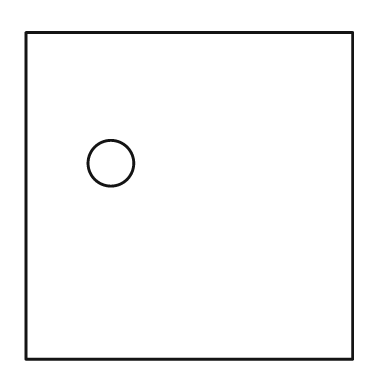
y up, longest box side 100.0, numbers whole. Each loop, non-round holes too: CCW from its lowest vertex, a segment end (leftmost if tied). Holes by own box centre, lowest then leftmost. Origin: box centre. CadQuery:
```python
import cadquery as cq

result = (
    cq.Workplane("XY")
    .moveTo(-50.0, -50.0)
    .lineTo(50.0, -50.0)
    .lineTo(50.0, 50.0)
    .lineTo(-50.0, 50.0)
    .close()
    .moveTo(-24.0, 10.0)
    .circle(7.0)
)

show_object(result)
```